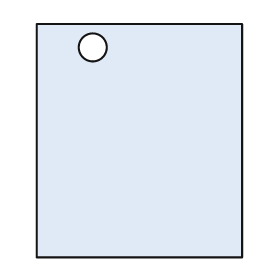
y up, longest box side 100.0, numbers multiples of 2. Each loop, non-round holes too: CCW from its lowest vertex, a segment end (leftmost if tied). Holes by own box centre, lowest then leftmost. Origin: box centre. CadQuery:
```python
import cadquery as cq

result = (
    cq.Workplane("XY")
    .moveTo(-44.0, -50.0)
    .lineTo(44.0, -50.0)
    .lineTo(44.0, 50.0)
    .lineTo(-44.0, 50.0)
    .close()
    .moveTo(-20.0, 40.0)
    .circle(6.0)
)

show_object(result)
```